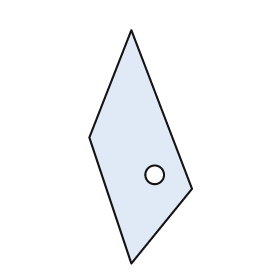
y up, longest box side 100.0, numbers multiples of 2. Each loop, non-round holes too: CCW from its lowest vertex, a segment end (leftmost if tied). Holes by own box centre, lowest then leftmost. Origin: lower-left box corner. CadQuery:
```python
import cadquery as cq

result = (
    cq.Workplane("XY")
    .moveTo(18.0, 0.0)
    .lineTo(44.0, 32.0)
    .lineTo(18.0, 100.0)
    .lineTo(0.0, 54.0)
    .close()
    .moveTo(28.0, 38.0)
    .circle(4.0)
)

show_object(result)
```